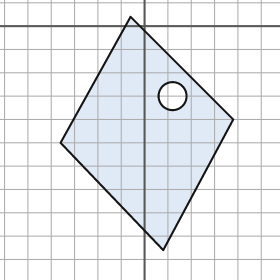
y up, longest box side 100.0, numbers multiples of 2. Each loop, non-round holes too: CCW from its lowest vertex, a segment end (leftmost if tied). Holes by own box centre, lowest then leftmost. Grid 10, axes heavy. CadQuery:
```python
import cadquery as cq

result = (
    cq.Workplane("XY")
    .moveTo(8.0, -96.0)
    .lineTo(38.0, -40.0)
    .lineTo(-6.0, 4.0)
    .lineTo(-36.0, -50.0)
    .close()
    .moveTo(12.0, -30.0)
    .circle(6.0)
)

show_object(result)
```